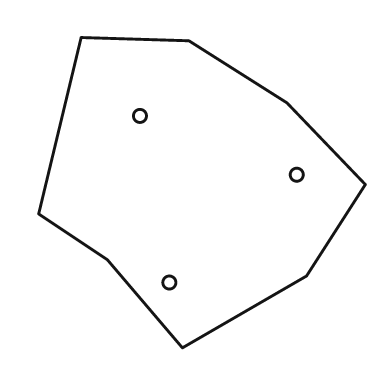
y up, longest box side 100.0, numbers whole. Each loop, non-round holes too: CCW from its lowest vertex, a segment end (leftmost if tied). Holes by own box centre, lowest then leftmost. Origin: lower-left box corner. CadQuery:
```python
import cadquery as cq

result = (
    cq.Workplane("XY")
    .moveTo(44.0, 0.0)
    .lineTo(82.0, 22.0)
    .lineTo(100.0, 50.0)
    .lineTo(76.0, 75.0)
    .lineTo(46.0, 94.0)
    .lineTo(13.0, 95.0)
    .lineTo(0.0, 41.0)
    .lineTo(21.0, 27.0)
    .close()
    .moveTo(40.0, 20.0)
    .circle(2.0)
    .moveTo(79.0, 53.0)
    .circle(2.0)
    .moveTo(31.0, 71.0)
    .circle(2.0)
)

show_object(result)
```